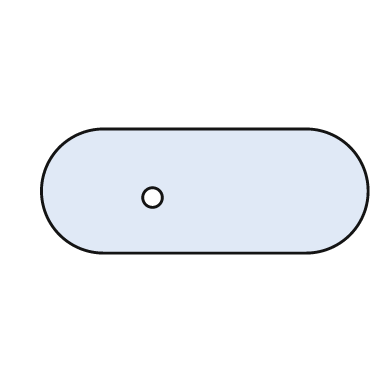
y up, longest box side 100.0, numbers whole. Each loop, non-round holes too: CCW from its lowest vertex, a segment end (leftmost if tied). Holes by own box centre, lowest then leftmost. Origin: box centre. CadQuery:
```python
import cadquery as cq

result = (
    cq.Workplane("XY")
    .moveTo(-31.0, -19.0)
    .lineTo(31.0, -19.0)
    .threePointArc((50.0, 0.0), (31.0, 19.0))
    .lineTo(-31.0, 19.0)
    .threePointArc((-50.0, 0.0), (-31.0, -19.0))
    .close()
    .moveTo(-16.0, -2.0)
    .circle(3.0)
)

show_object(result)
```